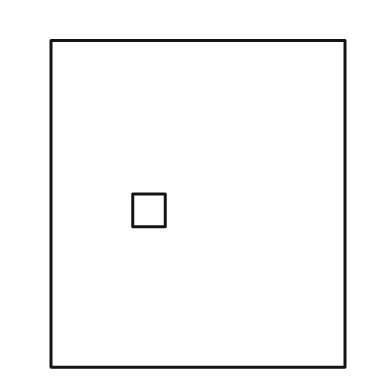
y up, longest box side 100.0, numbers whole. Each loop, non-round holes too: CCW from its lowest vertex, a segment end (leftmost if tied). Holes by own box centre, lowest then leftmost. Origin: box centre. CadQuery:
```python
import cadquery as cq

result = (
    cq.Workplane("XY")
    .moveTo(-45.0, -50.0)
    .lineTo(45.0, -50.0)
    .lineTo(45.0, 50.0)
    .lineTo(-45.0, 50.0)
    .close()
    .moveTo(-20.0, -7.0)
    .lineTo(-10.0, -7.0)
    .lineTo(-10.0, 3.0)
    .lineTo(-20.0, 3.0)
    .close()
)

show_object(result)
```